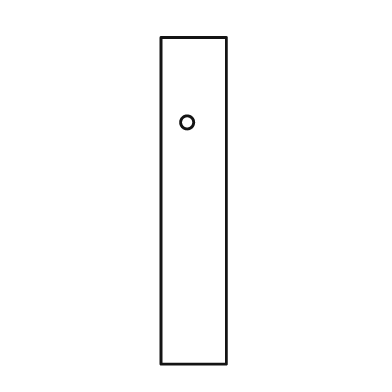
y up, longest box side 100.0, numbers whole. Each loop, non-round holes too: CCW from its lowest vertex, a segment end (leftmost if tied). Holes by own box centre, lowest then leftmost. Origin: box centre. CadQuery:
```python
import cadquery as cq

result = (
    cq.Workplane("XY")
    .moveTo(-10.0, -50.0)
    .lineTo(10.0, -50.0)
    .lineTo(10.0, 50.0)
    .lineTo(-10.0, 50.0)
    .close()
    .moveTo(-2.0, 24.0)
    .circle(2.0)
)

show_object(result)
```